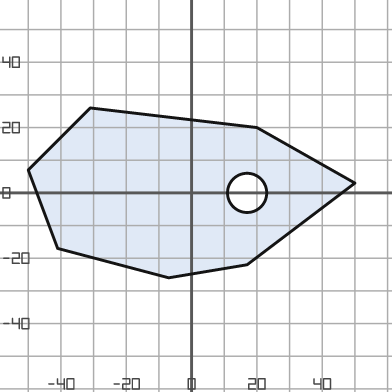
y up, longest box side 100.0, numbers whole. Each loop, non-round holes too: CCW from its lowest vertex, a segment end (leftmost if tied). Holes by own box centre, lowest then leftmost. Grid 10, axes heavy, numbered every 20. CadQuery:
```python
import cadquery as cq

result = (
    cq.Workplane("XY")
    .moveTo(-7.0, -26.0)
    .lineTo(17.0, -22.0)
    .lineTo(50.0, 3.0)
    .lineTo(20.0, 20.0)
    .lineTo(-31.0, 26.0)
    .lineTo(-50.0, 7.0)
    .lineTo(-41.0, -17.0)
    .close()
    .moveTo(17.0, 0.0)
    .circle(6.0)
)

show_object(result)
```